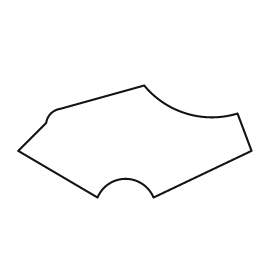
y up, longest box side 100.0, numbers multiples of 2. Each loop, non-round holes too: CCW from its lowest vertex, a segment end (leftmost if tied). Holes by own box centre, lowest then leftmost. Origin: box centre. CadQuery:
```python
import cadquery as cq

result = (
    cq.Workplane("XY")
    .moveTo(-16.0, -24.0)
    .threePointArc((-4.0, -16.0), (8.0, -24.0))
    .lineTo(50.0, -4.0)
    .lineTo(44.0, 12.0)
    .threePointArc((22.0, 12.0), (4.0, 24.0))
    .lineTo(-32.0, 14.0)
    .threePointArc((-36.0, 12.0), (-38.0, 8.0))
    .lineTo(-50.0, -4.0)
    .close()
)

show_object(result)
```